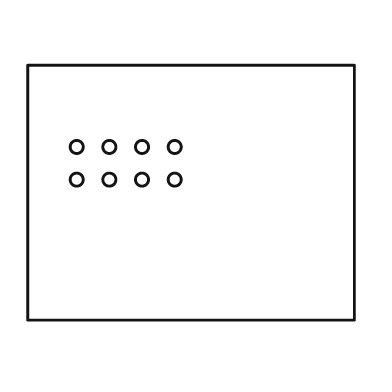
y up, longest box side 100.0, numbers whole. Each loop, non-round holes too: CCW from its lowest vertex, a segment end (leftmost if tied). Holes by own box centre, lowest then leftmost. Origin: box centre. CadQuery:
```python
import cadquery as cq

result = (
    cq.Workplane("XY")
    .moveTo(-50.0, -39.0)
    .lineTo(50.0, -39.0)
    .lineTo(50.0, 39.0)
    .lineTo(-50.0, 39.0)
    .close()
    .moveTo(-35.0, 4.0)
    .circle(2.0)
    .moveTo(-25.0, 4.0)
    .circle(2.0)
    .moveTo(-15.0, 4.0)
    .circle(2.0)
    .moveTo(-5.0, 4.0)
    .circle(2.0)
    .moveTo(-35.0, 14.0)
    .circle(2.0)
    .moveTo(-25.0, 14.0)
    .circle(2.0)
    .moveTo(-15.0, 14.0)
    .circle(2.0)
    .moveTo(-5.0, 14.0)
    .circle(2.0)
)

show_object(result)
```